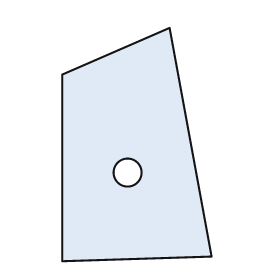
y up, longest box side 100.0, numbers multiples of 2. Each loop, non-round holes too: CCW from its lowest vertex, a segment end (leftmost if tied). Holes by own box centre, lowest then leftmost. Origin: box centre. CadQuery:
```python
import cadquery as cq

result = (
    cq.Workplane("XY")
    .moveTo(-32.0, -50.0)
    .lineTo(32.0, -48.0)
    .lineTo(14.0, 50.0)
    .lineTo(-32.0, 30.0)
    .close()
    .moveTo(-4.0, -12.0)
    .circle(6.0)
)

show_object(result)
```